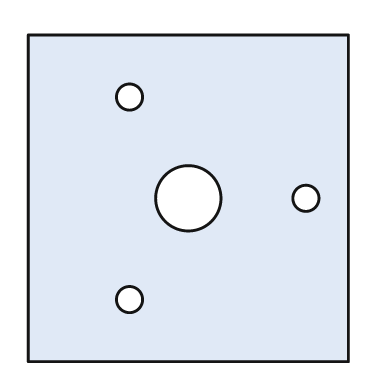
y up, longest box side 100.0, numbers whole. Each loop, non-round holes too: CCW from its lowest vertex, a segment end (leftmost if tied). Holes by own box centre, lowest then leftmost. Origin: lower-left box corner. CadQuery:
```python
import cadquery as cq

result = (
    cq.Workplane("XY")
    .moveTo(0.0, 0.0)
    .lineTo(98.0, 0.0)
    .lineTo(98.0, 100.0)
    .lineTo(0.0, 100.0)
    .close()
    .moveTo(31.0, 19.0)
    .circle(4.0)
    .moveTo(49.0, 50.0)
    .circle(10.0)
    .moveTo(85.0, 50.0)
    .circle(4.0)
    .moveTo(31.0, 81.0)
    .circle(4.0)
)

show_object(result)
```